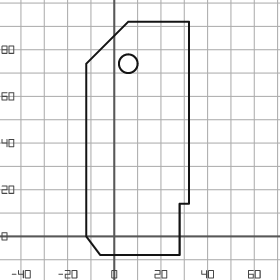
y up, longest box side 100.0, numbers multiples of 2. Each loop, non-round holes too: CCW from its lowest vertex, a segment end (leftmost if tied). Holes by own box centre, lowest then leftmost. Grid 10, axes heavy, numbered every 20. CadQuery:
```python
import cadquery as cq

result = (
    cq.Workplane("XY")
    .moveTo(-6.0, -8.0)
    .lineTo(28.0, -8.0)
    .lineTo(28.0, 14.0)
    .lineTo(32.0, 14.0)
    .lineTo(32.0, 92.0)
    .lineTo(6.0, 92.0)
    .lineTo(-12.0, 74.0)
    .lineTo(-12.0, 0.0)
    .close()
    .moveTo(6.0, 74.0)
    .circle(4.0)
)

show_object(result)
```